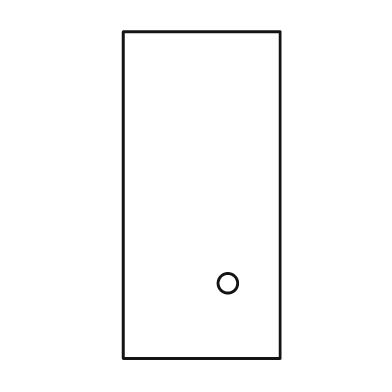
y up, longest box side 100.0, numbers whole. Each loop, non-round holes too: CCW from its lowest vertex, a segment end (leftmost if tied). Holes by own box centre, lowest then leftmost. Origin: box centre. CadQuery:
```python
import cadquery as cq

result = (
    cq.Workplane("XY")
    .moveTo(-24.0, -50.0)
    .lineTo(24.0, -50.0)
    .lineTo(24.0, 50.0)
    .lineTo(-24.0, 50.0)
    .close()
    .moveTo(8.0, -27.0)
    .circle(3.0)
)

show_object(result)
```